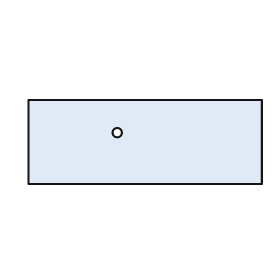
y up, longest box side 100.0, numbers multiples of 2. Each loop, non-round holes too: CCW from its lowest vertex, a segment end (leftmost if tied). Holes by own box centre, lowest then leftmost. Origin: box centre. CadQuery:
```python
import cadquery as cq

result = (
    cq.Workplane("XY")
    .moveTo(-50.0, -18.0)
    .lineTo(50.0, -18.0)
    .lineTo(50.0, 18.0)
    .lineTo(-50.0, 18.0)
    .close()
    .moveTo(-12.0, 4.0)
    .circle(2.0)
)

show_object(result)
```